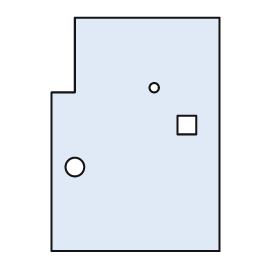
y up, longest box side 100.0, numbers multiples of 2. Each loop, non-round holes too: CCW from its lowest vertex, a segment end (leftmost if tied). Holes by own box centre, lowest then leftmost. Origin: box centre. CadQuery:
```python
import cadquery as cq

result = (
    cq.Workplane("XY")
    .moveTo(-36.0, -50.0)
    .lineTo(36.0, -50.0)
    .lineTo(36.0, 50.0)
    .lineTo(-26.0, 50.0)
    .lineTo(-26.0, 18.0)
    .lineTo(-36.0, 18.0)
    .close()
    .moveTo(-26.0, -14.0)
    .circle(4.0)
    .moveTo(18.0, 0.0)
    .lineTo(26.0, 0.0)
    .lineTo(26.0, 8.0)
    .lineTo(18.0, 8.0)
    .close()
    .moveTo(8.0, 20.0)
    .circle(2.0)
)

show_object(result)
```